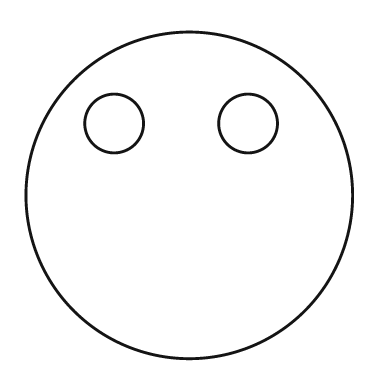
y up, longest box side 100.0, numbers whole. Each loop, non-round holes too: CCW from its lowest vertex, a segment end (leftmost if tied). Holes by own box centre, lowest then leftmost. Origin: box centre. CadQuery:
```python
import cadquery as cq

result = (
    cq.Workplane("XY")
    .moveTo(0.0, 0.0)
    .circle(50.0)
    .moveTo(-23.0, 22.0)
    .circle(9.0)
    .moveTo(18.0, 22.0)
    .circle(9.0)
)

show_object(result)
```